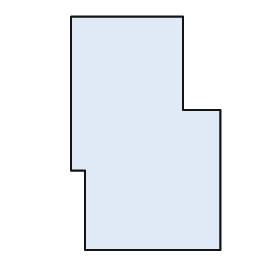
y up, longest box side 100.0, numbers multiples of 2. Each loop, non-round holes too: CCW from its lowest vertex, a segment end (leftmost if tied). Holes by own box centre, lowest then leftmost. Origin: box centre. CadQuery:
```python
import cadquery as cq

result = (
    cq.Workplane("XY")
    .moveTo(-26.0, -50.0)
    .lineTo(32.0, -50.0)
    .lineTo(32.0, 10.0)
    .lineTo(16.0, 10.0)
    .lineTo(16.0, 50.0)
    .lineTo(-32.0, 50.0)
    .lineTo(-32.0, -16.0)
    .lineTo(-26.0, -16.0)
    .close()
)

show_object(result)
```